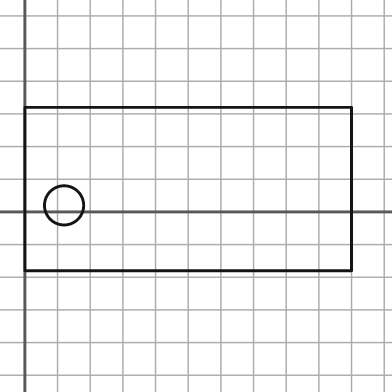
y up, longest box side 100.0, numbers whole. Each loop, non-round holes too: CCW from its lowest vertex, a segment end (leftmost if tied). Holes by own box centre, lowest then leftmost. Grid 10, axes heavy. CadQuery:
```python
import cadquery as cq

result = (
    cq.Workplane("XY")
    .moveTo(0.0, -18.0)
    .lineTo(100.0, -18.0)
    .lineTo(100.0, 32.0)
    .lineTo(0.0, 32.0)
    .close()
    .moveTo(12.0, 2.0)
    .circle(6.0)
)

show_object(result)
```